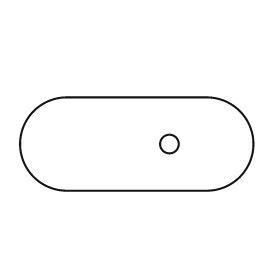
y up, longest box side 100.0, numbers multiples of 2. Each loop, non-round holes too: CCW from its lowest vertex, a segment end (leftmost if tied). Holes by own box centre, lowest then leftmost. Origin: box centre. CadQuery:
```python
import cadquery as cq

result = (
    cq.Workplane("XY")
    .moveTo(-30.0, -20.0)
    .lineTo(30.0, -20.0)
    .threePointArc((50.0, 0.0), (30.0, 20.0))
    .lineTo(-30.0, 20.0)
    .threePointArc((-50.0, 0.0), (-30.0, -20.0))
    .close()
    .moveTo(14.0, 0.0)
    .circle(4.0)
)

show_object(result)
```